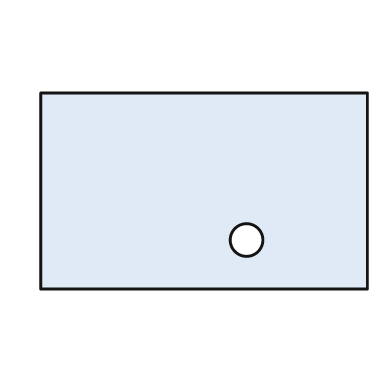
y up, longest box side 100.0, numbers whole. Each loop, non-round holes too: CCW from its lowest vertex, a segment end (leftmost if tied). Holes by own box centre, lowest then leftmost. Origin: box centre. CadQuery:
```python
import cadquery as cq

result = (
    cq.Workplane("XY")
    .moveTo(-50.0, -30.0)
    .lineTo(50.0, -30.0)
    .lineTo(50.0, 30.0)
    .lineTo(-50.0, 30.0)
    .close()
    .moveTo(13.0, -15.0)
    .circle(5.0)
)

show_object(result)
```